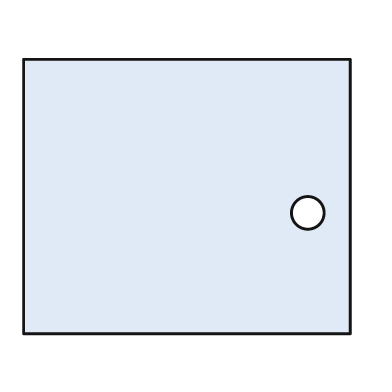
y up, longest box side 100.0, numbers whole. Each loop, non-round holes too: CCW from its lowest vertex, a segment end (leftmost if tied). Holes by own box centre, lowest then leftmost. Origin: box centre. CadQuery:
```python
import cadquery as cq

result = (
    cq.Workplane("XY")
    .moveTo(-50.0, -42.0)
    .lineTo(50.0, -42.0)
    .lineTo(50.0, 42.0)
    .lineTo(-50.0, 42.0)
    .close()
    .moveTo(37.0, -5.0)
    .circle(5.0)
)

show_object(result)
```